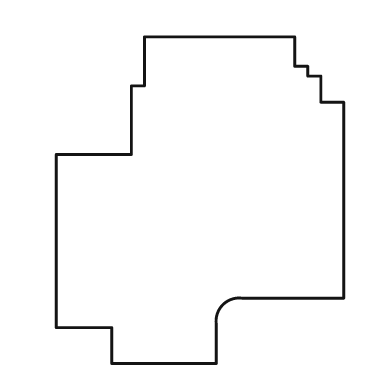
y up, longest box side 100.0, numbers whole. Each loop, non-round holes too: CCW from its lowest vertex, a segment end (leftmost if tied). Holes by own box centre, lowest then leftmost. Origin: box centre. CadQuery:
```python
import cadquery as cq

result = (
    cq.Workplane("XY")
    .moveTo(-27.0, -50.0)
    .lineTo(5.0, -50.0)
    .lineTo(5.0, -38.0)
    .threePointArc((7.0, -32.0), (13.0, -30.0))
    .lineTo(44.0, -30.0)
    .lineTo(44.0, 30.0)
    .lineTo(37.0, 30.0)
    .lineTo(37.0, 38.0)
    .lineTo(33.0, 38.0)
    .lineTo(33.0, 41.0)
    .lineTo(29.0, 41.0)
    .lineTo(29.0, 50.0)
    .lineTo(-17.0, 50.0)
    .lineTo(-17.0, 35.0)
    .lineTo(-21.0, 35.0)
    .lineTo(-21.0, 14.0)
    .lineTo(-44.0, 14.0)
    .lineTo(-44.0, -39.0)
    .lineTo(-27.0, -39.0)
    .close()
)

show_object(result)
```